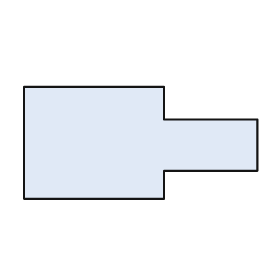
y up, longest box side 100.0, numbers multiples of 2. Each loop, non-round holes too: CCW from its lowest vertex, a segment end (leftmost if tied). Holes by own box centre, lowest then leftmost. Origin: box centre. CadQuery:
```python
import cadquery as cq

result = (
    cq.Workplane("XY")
    .moveTo(-50.0, -24.0)
    .lineTo(10.0, -24.0)
    .lineTo(10.0, -12.0)
    .lineTo(50.0, -12.0)
    .lineTo(50.0, 10.0)
    .lineTo(10.0, 10.0)
    .lineTo(10.0, 24.0)
    .lineTo(-50.0, 24.0)
    .close()
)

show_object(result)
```